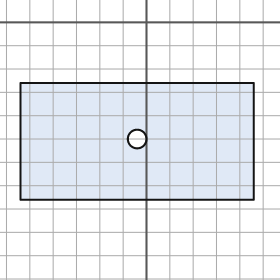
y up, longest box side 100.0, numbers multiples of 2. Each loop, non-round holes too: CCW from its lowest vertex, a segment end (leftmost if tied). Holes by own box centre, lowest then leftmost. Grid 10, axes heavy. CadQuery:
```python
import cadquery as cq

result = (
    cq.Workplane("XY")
    .moveTo(-54.0, -76.0)
    .lineTo(46.0, -76.0)
    .lineTo(46.0, -26.0)
    .lineTo(-54.0, -26.0)
    .close()
    .moveTo(-4.0, -50.0)
    .circle(4.0)
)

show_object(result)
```